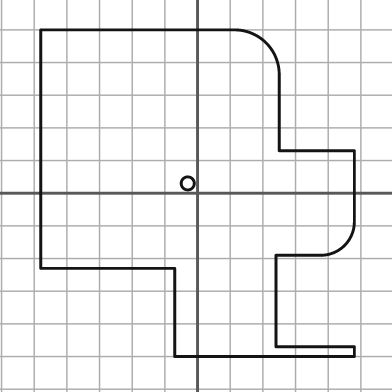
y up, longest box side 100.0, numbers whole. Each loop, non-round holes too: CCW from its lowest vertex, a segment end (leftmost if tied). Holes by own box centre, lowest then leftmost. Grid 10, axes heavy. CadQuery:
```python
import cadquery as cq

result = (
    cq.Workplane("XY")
    .moveTo(-7.0, -50.0)
    .lineTo(48.0, -50.0)
    .lineTo(48.0, -47.0)
    .lineTo(24.0, -47.0)
    .lineTo(24.0, -19.0)
    .lineTo(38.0, -19.0)
    .threePointArc((45.0, -16.0), (48.0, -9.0))
    .lineTo(48.0, 13.0)
    .lineTo(25.0, 13.0)
    .lineTo(25.0, 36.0)
    .threePointArc((21.0, 46.0), (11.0, 50.0))
    .lineTo(-48.0, 50.0)
    .lineTo(-48.0, -23.0)
    .lineTo(-7.0, -23.0)
    .close()
    .moveTo(-3.0, 3.0)
    .circle(2.0)
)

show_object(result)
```